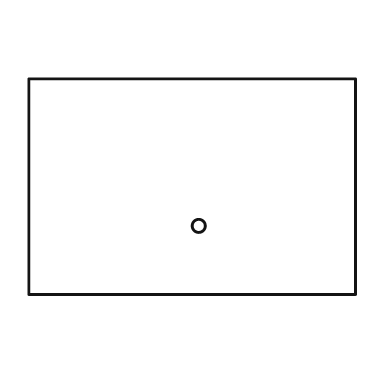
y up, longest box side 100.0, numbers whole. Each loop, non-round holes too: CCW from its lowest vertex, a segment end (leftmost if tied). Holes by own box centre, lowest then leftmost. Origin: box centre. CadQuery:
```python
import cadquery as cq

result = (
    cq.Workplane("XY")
    .moveTo(-50.0, -33.0)
    .lineTo(50.0, -33.0)
    .lineTo(50.0, 33.0)
    .lineTo(-50.0, 33.0)
    .close()
    .moveTo(2.0, -12.0)
    .circle(2.0)
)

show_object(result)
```